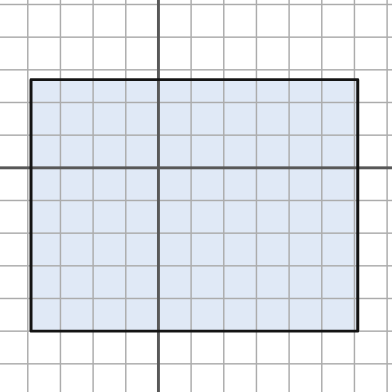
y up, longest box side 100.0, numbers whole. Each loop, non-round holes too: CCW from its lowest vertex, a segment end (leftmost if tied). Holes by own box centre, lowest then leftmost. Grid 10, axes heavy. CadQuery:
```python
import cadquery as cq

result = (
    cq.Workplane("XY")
    .moveTo(-39.0, -50.0)
    .lineTo(61.0, -50.0)
    .lineTo(61.0, 27.0)
    .lineTo(-39.0, 27.0)
    .close()
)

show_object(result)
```